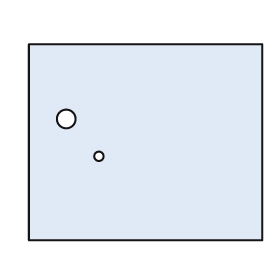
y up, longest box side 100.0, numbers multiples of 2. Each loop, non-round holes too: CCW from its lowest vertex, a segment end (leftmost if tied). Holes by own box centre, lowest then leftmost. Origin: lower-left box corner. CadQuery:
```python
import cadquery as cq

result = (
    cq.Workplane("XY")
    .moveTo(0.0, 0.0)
    .lineTo(100.0, 0.0)
    .lineTo(100.0, 84.0)
    .lineTo(0.0, 84.0)
    .close()
    .moveTo(30.0, 36.0)
    .circle(2.0)
    .moveTo(16.0, 52.0)
    .circle(4.0)
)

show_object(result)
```